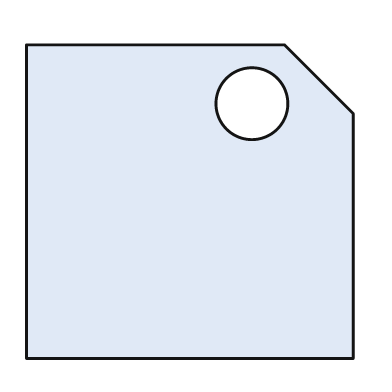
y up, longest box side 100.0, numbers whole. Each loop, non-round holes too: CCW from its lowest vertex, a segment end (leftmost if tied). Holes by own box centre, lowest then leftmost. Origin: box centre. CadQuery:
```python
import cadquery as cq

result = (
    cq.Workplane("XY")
    .moveTo(-50.0, -48.0)
    .lineTo(50.0, -48.0)
    .lineTo(50.0, 27.0)
    .lineTo(29.0, 48.0)
    .lineTo(-50.0, 48.0)
    .close()
    .moveTo(19.0, 30.0)
    .circle(11.0)
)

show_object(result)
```